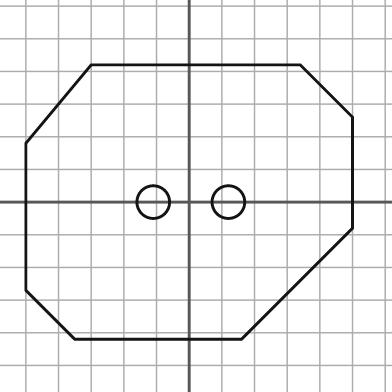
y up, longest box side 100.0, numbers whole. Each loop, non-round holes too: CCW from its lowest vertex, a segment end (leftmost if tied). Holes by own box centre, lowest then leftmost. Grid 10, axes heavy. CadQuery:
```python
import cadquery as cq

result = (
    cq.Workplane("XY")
    .moveTo(-35.0, -42.0)
    .lineTo(16.0, -42.0)
    .lineTo(50.0, -8.0)
    .lineTo(50.0, 26.0)
    .lineTo(34.0, 42.0)
    .lineTo(-30.0, 42.0)
    .lineTo(-50.0, 18.0)
    .lineTo(-50.0, -27.0)
    .close()
    .moveTo(-11.0, 0.0)
    .circle(5.0)
    .moveTo(12.0, 0.0)
    .circle(5.0)
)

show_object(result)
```